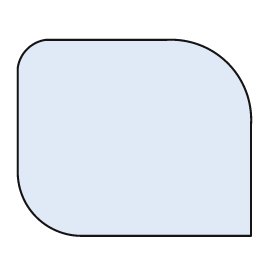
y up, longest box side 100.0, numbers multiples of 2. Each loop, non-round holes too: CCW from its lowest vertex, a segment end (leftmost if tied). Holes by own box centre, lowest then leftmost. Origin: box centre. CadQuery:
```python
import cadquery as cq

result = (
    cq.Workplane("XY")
    .moveTo(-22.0, -42.0)
    .lineTo(50.0, -42.0)
    .lineTo(50.0, 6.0)
    .threePointArc((40.0, 32.0), (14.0, 42.0))
    .lineTo(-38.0, 42.0)
    .threePointArc((-46.0, 38.0), (-50.0, 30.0))
    .lineTo(-50.0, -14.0)
    .threePointArc((-42.0, -34.0), (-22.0, -42.0))
    .close()
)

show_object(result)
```